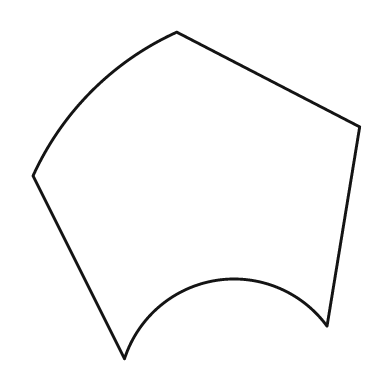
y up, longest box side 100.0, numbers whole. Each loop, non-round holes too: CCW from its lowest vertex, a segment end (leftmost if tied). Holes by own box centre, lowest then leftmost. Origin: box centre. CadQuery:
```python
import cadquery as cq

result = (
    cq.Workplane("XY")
    .moveTo(-22.0, -50.0)
    .threePointArc((6.0, -26.0), (40.0, -40.0))
    .lineTo(50.0, 21.0)
    .lineTo(-6.0, 50.0)
    .threePointArc((-32.0, 32.0), (-50.0, 6.0))
    .close()
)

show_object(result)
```